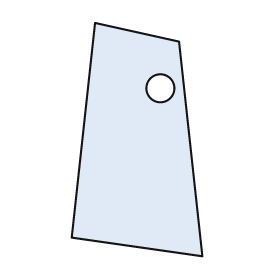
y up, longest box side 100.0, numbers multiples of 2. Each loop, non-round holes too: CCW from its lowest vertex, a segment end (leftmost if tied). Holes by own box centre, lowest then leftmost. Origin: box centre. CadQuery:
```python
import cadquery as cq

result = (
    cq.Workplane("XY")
    .moveTo(28.0, -50.0)
    .lineTo(18.0, 42.0)
    .lineTo(-18.0, 50.0)
    .lineTo(-28.0, -42.0)
    .close()
    .moveTo(10.0, 22.0)
    .circle(6.0)
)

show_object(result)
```